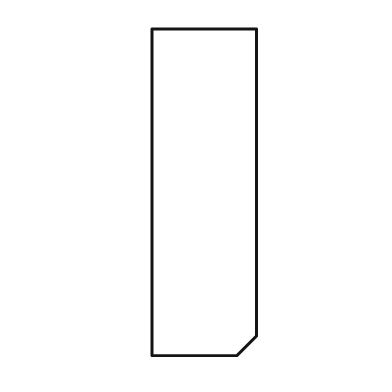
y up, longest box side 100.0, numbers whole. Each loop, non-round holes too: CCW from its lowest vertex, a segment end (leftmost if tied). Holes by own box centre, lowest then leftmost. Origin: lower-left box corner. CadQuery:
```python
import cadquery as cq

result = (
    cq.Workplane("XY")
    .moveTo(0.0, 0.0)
    .lineTo(26.0, 0.0)
    .lineTo(32.0, 6.0)
    .lineTo(32.0, 100.0)
    .lineTo(0.0, 100.0)
    .close()
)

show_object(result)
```